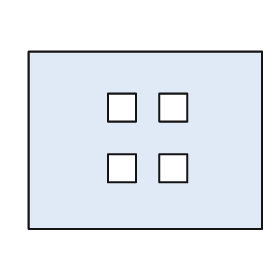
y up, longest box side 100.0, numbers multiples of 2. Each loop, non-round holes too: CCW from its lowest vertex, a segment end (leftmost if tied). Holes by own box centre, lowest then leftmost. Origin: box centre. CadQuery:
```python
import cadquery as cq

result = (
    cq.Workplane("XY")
    .moveTo(-50.0, -38.0)
    .lineTo(50.0, -38.0)
    .lineTo(50.0, 38.0)
    .lineTo(-50.0, 38.0)
    .close()
    .moveTo(-16.0, -18.0)
    .lineTo(-4.0, -18.0)
    .lineTo(-4.0, -6.0)
    .lineTo(-16.0, -6.0)
    .close()
    .moveTo(6.0, -18.0)
    .lineTo(18.0, -18.0)
    .lineTo(18.0, -6.0)
    .lineTo(6.0, -6.0)
    .close()
    .moveTo(-16.0, 8.0)
    .lineTo(-4.0, 8.0)
    .lineTo(-4.0, 20.0)
    .lineTo(-16.0, 20.0)
    .close()
    .moveTo(6.0, 8.0)
    .lineTo(18.0, 8.0)
    .lineTo(18.0, 20.0)
    .lineTo(6.0, 20.0)
    .close()
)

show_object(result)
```